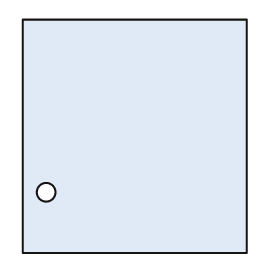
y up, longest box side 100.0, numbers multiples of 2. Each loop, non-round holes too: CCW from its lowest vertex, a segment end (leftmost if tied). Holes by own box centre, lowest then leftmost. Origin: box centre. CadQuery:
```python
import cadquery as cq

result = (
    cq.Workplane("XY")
    .moveTo(-48.0, -50.0)
    .lineTo(48.0, -50.0)
    .lineTo(48.0, 50.0)
    .lineTo(-48.0, 50.0)
    .close()
    .moveTo(-38.0, -24.0)
    .circle(4.0)
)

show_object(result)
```